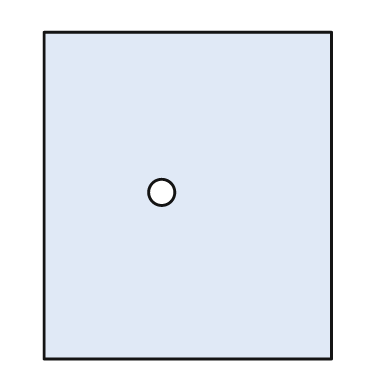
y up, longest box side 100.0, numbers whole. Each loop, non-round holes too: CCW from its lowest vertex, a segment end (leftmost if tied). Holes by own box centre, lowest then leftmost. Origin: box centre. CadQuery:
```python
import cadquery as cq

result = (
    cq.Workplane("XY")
    .moveTo(-44.0, -50.0)
    .lineTo(44.0, -50.0)
    .lineTo(44.0, 50.0)
    .lineTo(-44.0, 50.0)
    .close()
    .moveTo(-8.0, 1.0)
    .circle(4.0)
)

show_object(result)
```